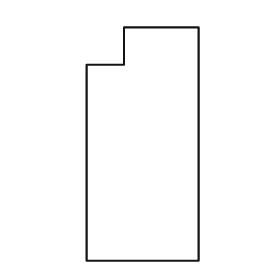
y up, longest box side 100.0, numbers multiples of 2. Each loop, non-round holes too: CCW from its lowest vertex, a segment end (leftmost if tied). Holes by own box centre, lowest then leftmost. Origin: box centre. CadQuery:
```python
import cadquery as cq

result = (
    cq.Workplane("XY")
    .moveTo(-24.0, -50.0)
    .lineTo(24.0, -50.0)
    .lineTo(24.0, 50.0)
    .lineTo(-8.0, 50.0)
    .lineTo(-8.0, 34.0)
    .lineTo(-24.0, 34.0)
    .close()
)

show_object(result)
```